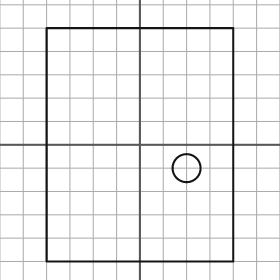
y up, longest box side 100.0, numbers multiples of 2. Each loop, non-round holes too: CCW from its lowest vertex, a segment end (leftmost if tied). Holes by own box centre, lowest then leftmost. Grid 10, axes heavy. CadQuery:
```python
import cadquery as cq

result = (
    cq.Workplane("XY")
    .moveTo(-40.0, -50.0)
    .lineTo(40.0, -50.0)
    .lineTo(40.0, 50.0)
    .lineTo(-40.0, 50.0)
    .close()
    .moveTo(20.0, -10.0)
    .circle(6.0)
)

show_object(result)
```